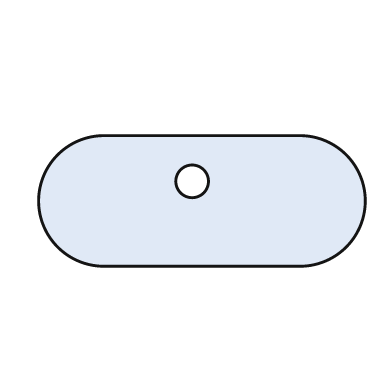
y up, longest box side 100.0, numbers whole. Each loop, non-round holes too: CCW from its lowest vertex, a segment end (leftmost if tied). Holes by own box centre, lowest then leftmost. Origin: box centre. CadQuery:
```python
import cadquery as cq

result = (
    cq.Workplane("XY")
    .moveTo(-30.0, -20.0)
    .lineTo(30.0, -20.0)
    .threePointArc((50.0, 0.0), (30.0, 20.0))
    .lineTo(-30.0, 20.0)
    .threePointArc((-50.0, 0.0), (-30.0, -20.0))
    .close()
    .moveTo(-3.0, 6.0)
    .circle(5.0)
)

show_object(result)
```